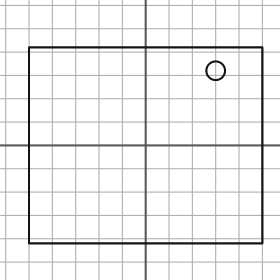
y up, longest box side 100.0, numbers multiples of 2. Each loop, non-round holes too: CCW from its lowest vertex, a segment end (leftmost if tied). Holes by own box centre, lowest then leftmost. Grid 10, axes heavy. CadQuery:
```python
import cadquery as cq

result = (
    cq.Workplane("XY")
    .moveTo(-50.0, -42.0)
    .lineTo(50.0, -42.0)
    .lineTo(50.0, 42.0)
    .lineTo(-50.0, 42.0)
    .close()
    .moveTo(30.0, 32.0)
    .circle(4.0)
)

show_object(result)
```